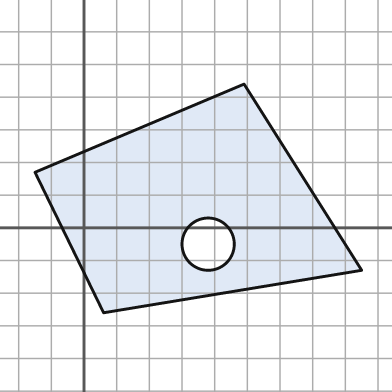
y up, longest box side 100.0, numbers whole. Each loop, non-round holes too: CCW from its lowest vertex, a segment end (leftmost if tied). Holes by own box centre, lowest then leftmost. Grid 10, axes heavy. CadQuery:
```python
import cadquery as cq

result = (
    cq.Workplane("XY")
    .moveTo(6.0, -26.0)
    .lineTo(85.0, -13.0)
    .lineTo(49.0, 44.0)
    .lineTo(-15.0, 17.0)
    .close()
    .moveTo(38.0, -5.0)
    .circle(8.0)
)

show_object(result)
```